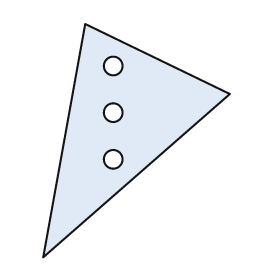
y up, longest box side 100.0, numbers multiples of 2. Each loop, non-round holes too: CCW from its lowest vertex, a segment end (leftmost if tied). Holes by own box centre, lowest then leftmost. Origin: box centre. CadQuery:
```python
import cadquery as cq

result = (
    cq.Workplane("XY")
    .moveTo(-40.0, -50.0)
    .lineTo(40.0, 20.0)
    .lineTo(-22.0, 50.0)
    .close()
    .moveTo(-10.0, -8.0)
    .circle(4.0)
    .moveTo(-10.0, 12.0)
    .circle(4.0)
    .moveTo(-10.0, 32.0)
    .circle(4.0)
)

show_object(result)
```